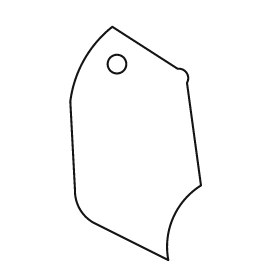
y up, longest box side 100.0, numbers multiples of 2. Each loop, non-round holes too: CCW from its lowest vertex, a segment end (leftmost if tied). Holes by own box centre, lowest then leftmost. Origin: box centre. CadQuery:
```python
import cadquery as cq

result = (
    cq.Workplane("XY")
    .moveTo(14.0, -50.0)
    .threePointArc((16.0, -32.0), (28.0, -18.0))
    .lineTo(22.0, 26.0)
    .threePointArc((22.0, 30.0), (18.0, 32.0))
    .lineTo(-10.0, 50.0)
    .threePointArc((-22.0, 36.0), (-28.0, 18.0))
    .lineTo(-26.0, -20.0)
    .threePointArc((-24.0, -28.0), (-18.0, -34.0))
    .close()
    .moveTo(-8.0, 34.0)
    .circle(4.0)
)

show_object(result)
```